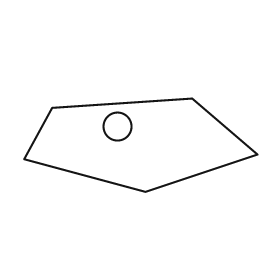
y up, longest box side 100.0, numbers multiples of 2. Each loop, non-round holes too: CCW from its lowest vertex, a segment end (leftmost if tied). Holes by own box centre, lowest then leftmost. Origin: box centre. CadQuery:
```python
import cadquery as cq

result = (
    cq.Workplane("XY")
    .moveTo(2.0, -20.0)
    .lineTo(50.0, -4.0)
    .lineTo(22.0, 20.0)
    .lineTo(-38.0, 16.0)
    .lineTo(-50.0, -6.0)
    .close()
    .moveTo(-10.0, 8.0)
    .circle(6.0)
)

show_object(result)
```